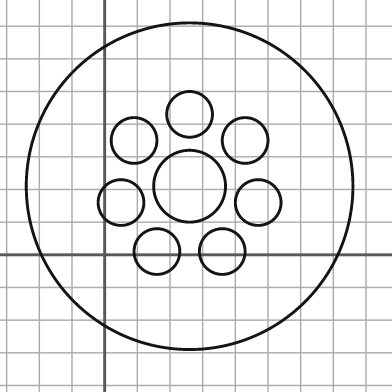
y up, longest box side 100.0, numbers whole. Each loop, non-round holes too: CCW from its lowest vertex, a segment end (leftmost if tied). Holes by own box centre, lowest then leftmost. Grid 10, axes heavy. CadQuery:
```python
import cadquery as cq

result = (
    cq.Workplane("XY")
    .moveTo(26.0, 21.0)
    .circle(50.0)
    .moveTo(16.0, 1.0)
    .circle(7.0)
    .moveTo(36.0, 1.0)
    .circle(7.0)
    .moveTo(5.0, 16.0)
    .circle(7.0)
    .moveTo(47.0, 16.0)
    .circle(7.0)
    .moveTo(26.0, 21.0)
    .circle(11.0)
    .moveTo(9.0, 35.0)
    .circle(7.0)
    .moveTo(43.0, 35.0)
    .circle(7.0)
    .moveTo(26.0, 43.0)
    .circle(7.0)
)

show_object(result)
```